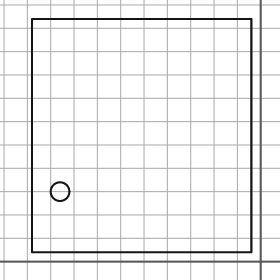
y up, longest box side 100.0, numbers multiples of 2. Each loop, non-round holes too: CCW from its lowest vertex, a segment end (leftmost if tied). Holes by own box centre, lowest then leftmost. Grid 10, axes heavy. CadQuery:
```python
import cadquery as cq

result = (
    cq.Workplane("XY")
    .moveTo(-98.0, 4.0)
    .lineTo(-4.0, 4.0)
    .lineTo(-4.0, 104.0)
    .lineTo(-98.0, 104.0)
    .close()
    .moveTo(-86.0, 30.0)
    .circle(4.0)
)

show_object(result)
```